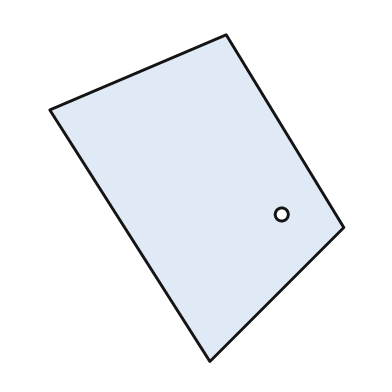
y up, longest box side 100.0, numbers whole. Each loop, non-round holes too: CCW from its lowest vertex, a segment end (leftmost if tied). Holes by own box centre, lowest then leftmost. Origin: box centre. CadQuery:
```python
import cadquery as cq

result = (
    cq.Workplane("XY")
    .moveTo(4.0, -50.0)
    .lineTo(45.0, -9.0)
    .lineTo(9.0, 50.0)
    .lineTo(-45.0, 27.0)
    .close()
    .moveTo(26.0, -5.0)
    .circle(2.0)
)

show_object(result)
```